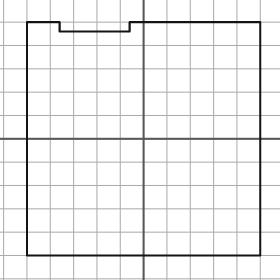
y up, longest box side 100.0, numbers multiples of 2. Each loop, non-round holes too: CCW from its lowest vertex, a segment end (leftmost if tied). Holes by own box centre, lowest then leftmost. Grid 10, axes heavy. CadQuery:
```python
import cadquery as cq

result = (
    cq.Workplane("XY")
    .moveTo(-50.0, -50.0)
    .lineTo(50.0, -50.0)
    .lineTo(50.0, 50.0)
    .lineTo(-6.0, 50.0)
    .lineTo(-6.0, 46.0)
    .lineTo(-36.0, 46.0)
    .lineTo(-36.0, 50.0)
    .lineTo(-50.0, 50.0)
    .close()
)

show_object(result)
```